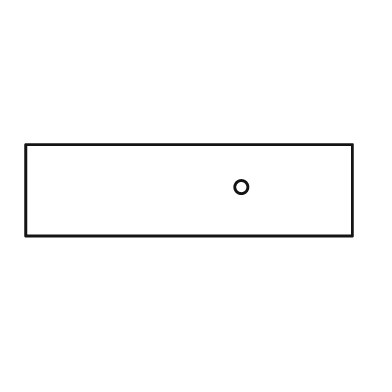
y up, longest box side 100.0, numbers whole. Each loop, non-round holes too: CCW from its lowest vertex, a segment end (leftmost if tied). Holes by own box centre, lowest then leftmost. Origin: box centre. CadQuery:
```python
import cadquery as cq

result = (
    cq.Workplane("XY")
    .moveTo(-50.0, -14.0)
    .lineTo(50.0, -14.0)
    .lineTo(50.0, 14.0)
    .lineTo(-50.0, 14.0)
    .close()
    .moveTo(16.0, 1.0)
    .circle(2.0)
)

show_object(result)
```